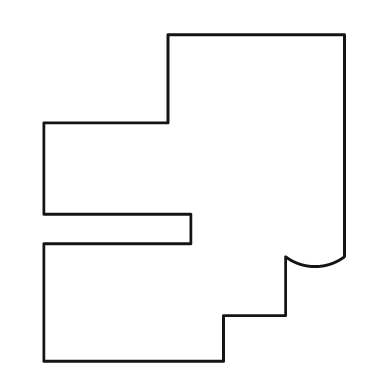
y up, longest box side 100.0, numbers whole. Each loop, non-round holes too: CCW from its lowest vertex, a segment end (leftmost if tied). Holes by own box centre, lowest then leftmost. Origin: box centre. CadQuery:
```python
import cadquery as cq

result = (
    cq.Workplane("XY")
    .moveTo(-46.0, -50.0)
    .lineTo(9.0, -50.0)
    .lineTo(9.0, -36.0)
    .lineTo(28.0, -36.0)
    .lineTo(28.0, -18.0)
    .threePointArc((37.0, -21.0), (46.0, -18.0))
    .lineTo(46.0, 50.0)
    .lineTo(-8.0, 50.0)
    .lineTo(-8.0, 23.0)
    .lineTo(-46.0, 23.0)
    .lineTo(-46.0, -5.0)
    .lineTo(-1.0, -5.0)
    .lineTo(-1.0, -14.0)
    .lineTo(-46.0, -14.0)
    .close()
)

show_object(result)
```